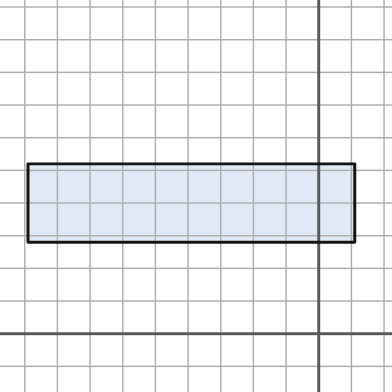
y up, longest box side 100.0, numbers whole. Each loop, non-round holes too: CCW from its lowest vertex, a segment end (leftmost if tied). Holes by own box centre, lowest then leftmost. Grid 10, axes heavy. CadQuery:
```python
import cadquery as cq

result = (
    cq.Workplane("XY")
    .moveTo(-89.0, 28.0)
    .lineTo(11.0, 28.0)
    .lineTo(11.0, 52.0)
    .lineTo(-89.0, 52.0)
    .close()
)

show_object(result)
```